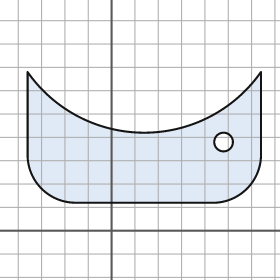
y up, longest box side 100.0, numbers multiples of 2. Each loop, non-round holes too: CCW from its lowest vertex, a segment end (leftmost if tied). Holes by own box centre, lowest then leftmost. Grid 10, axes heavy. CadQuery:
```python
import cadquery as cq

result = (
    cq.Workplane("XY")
    .moveTo(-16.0, 12.0)
    .lineTo(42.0, 12.0)
    .threePointArc((58.0, 18.0), (64.0, 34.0))
    .lineTo(64.0, 68.0)
    .threePointArc((14.0, 42.0), (-36.0, 68.0))
    .lineTo(-36.0, 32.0)
    .threePointArc((-30.0, 18.0), (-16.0, 12.0))
    .close()
    .moveTo(48.0, 38.0)
    .circle(4.0)
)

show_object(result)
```